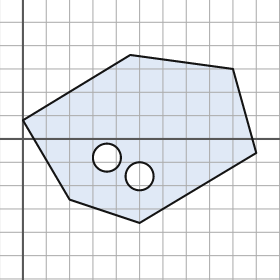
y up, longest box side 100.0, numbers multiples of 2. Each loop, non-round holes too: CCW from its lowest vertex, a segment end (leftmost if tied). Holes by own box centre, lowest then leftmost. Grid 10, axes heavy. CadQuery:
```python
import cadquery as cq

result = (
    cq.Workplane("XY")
    .moveTo(50.0, -36.0)
    .lineTo(100.0, -6.0)
    .lineTo(90.0, 30.0)
    .lineTo(46.0, 36.0)
    .lineTo(0.0, 8.0)
    .lineTo(20.0, -26.0)
    .close()
    .moveTo(50.0, -16.0)
    .circle(6.0)
    .moveTo(36.0, -8.0)
    .circle(6.0)
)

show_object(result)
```